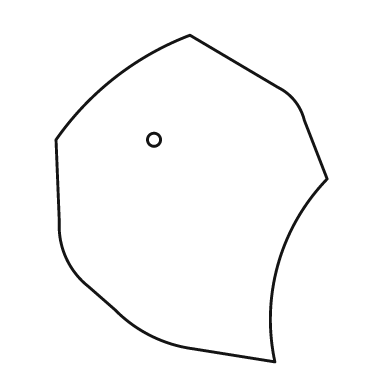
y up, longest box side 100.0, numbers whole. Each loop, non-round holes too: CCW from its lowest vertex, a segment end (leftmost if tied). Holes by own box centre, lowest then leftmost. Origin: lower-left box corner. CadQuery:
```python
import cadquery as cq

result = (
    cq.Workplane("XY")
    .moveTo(67.0, 0.0)
    .threePointArc((68.0, 30.0), (83.0, 56.0))
    .lineTo(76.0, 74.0)
    .threePointArc((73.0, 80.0), (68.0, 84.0))
    .lineTo(41.0, 100.0)
    .threePointArc((18.0, 87.0), (0.0, 68.0))
    .lineTo(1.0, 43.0)
    .threePointArc((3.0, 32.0), (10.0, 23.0))
    .lineTo(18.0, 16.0)
    .threePointArc((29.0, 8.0), (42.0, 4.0))
    .close()
    .moveTo(30.0, 68.0)
    .circle(2.0)
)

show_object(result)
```